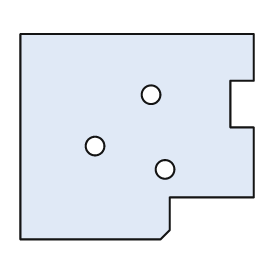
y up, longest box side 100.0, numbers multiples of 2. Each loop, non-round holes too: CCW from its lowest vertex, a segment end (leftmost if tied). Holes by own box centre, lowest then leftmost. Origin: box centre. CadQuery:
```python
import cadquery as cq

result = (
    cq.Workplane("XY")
    .moveTo(-50.0, -44.0)
    .lineTo(10.0, -44.0)
    .lineTo(14.0, -40.0)
    .lineTo(14.0, -26.0)
    .lineTo(50.0, -26.0)
    .lineTo(50.0, 4.0)
    .lineTo(40.0, 4.0)
    .lineTo(40.0, 24.0)
    .lineTo(50.0, 24.0)
    .lineTo(50.0, 44.0)
    .lineTo(-50.0, 44.0)
    .close()
    .moveTo(12.0, -14.0)
    .circle(4.0)
    .moveTo(-18.0, -4.0)
    .circle(4.0)
    .moveTo(6.0, 18.0)
    .circle(4.0)
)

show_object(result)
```